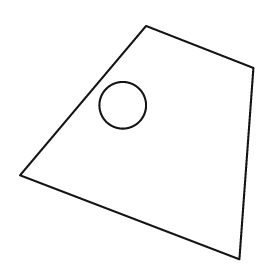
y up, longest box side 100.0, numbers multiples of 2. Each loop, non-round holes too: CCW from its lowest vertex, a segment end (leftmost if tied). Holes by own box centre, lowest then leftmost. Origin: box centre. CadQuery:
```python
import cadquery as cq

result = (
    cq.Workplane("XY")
    .moveTo(44.0, -50.0)
    .lineTo(50.0, 32.0)
    .lineTo(4.0, 50.0)
    .lineTo(-50.0, -14.0)
    .close()
    .moveTo(-6.0, 16.0)
    .circle(10.0)
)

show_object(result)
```